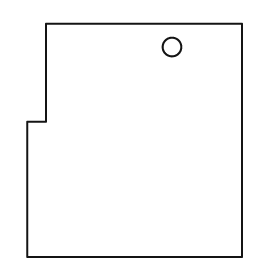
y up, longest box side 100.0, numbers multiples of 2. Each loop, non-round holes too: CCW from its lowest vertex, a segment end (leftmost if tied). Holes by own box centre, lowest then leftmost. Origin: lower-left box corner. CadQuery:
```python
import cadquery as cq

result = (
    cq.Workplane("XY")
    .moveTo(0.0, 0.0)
    .lineTo(92.0, 0.0)
    .lineTo(92.0, 100.0)
    .lineTo(8.0, 100.0)
    .lineTo(8.0, 58.0)
    .lineTo(0.0, 58.0)
    .close()
    .moveTo(62.0, 90.0)
    .circle(4.0)
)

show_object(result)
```